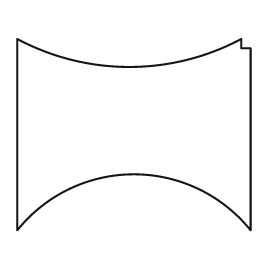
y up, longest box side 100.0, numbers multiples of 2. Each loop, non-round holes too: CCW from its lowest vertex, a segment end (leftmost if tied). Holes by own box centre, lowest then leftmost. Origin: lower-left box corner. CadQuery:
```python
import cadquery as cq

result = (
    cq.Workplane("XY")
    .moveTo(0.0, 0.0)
    .threePointArc((50.0, 24.0), (100.0, 0.0))
    .lineTo(100.0, 78.0)
    .lineTo(96.0, 78.0)
    .lineTo(96.0, 82.0)
    .threePointArc((48.0, 70.0), (0.0, 82.0))
    .close()
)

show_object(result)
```